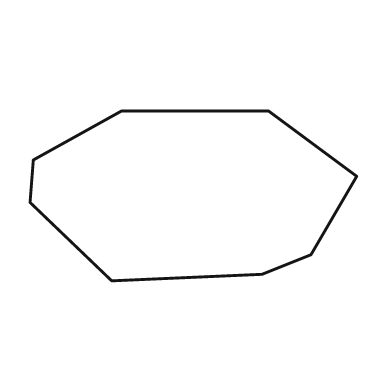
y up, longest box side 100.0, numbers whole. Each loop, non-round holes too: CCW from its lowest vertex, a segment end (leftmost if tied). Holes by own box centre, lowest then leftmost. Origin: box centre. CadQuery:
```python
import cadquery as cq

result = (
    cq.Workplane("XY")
    .moveTo(-25.0, -26.0)
    .lineTo(21.0, -24.0)
    .lineTo(36.0, -18.0)
    .lineTo(50.0, 6.0)
    .lineTo(23.0, 26.0)
    .lineTo(-22.0, 26.0)
    .lineTo(-49.0, 11.0)
    .lineTo(-50.0, -2.0)
    .close()
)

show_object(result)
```